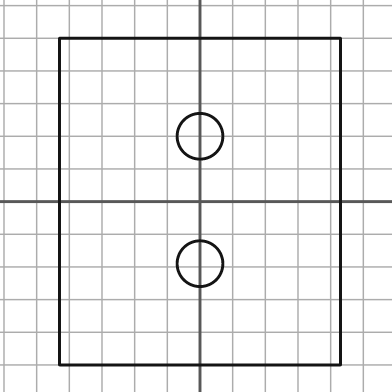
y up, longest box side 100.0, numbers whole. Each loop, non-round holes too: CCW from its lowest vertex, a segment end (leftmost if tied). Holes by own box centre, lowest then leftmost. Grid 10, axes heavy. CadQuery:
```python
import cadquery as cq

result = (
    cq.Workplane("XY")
    .moveTo(-43.0, -50.0)
    .lineTo(43.0, -50.0)
    .lineTo(43.0, 50.0)
    .lineTo(-43.0, 50.0)
    .close()
    .moveTo(0.0, -19.0)
    .circle(7.0)
    .moveTo(0.0, 20.0)
    .circle(7.0)
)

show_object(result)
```